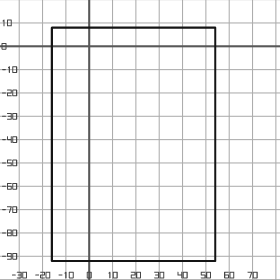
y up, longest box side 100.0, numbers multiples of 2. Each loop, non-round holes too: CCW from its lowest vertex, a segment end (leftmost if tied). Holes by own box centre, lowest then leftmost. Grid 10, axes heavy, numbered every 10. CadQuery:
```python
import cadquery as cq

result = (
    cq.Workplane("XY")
    .moveTo(-16.0, -92.0)
    .lineTo(54.0, -92.0)
    .lineTo(54.0, 8.0)
    .lineTo(-16.0, 8.0)
    .close()
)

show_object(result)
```